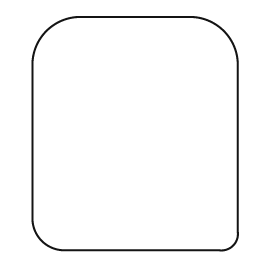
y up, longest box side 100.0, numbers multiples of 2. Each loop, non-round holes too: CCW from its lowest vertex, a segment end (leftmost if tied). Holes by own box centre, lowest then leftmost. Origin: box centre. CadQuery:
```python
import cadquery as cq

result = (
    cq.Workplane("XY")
    .moveTo(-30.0, -50.0)
    .lineTo(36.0, -50.0)
    .threePointArc((42.0, -48.0), (44.0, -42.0))
    .lineTo(44.0, 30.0)
    .threePointArc((38.0, 44.0), (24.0, 50.0))
    .lineTo(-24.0, 50.0)
    .threePointArc((-38.0, 44.0), (-44.0, 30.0))
    .lineTo(-44.0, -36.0)
    .threePointArc((-40.0, -46.0), (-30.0, -50.0))
    .close()
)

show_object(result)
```